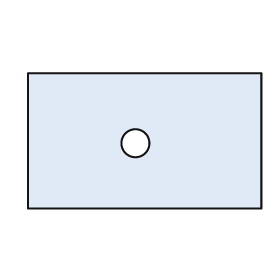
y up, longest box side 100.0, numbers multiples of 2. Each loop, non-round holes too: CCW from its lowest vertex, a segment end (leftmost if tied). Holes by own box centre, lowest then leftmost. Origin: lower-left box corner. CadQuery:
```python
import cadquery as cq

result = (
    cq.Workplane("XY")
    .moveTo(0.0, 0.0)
    .lineTo(100.0, 0.0)
    .lineTo(100.0, 58.0)
    .lineTo(0.0, 58.0)
    .close()
    .moveTo(46.0, 28.0)
    .circle(6.0)
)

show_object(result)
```